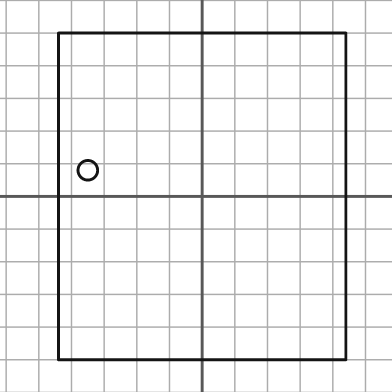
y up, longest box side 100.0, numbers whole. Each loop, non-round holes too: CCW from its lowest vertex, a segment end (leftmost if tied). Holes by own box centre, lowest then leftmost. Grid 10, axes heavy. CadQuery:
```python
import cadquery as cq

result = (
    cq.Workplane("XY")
    .moveTo(-44.0, -50.0)
    .lineTo(44.0, -50.0)
    .lineTo(44.0, 50.0)
    .lineTo(-44.0, 50.0)
    .close()
    .moveTo(-35.0, 8.0)
    .circle(3.0)
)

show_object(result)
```